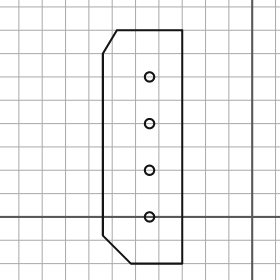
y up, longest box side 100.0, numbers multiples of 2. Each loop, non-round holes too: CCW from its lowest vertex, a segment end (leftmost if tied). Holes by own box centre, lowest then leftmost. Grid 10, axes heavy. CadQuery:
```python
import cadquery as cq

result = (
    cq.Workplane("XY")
    .moveTo(-52.0, -20.0)
    .lineTo(-30.0, -20.0)
    .lineTo(-30.0, 80.0)
    .lineTo(-58.0, 80.0)
    .lineTo(-64.0, 70.0)
    .lineTo(-64.0, -8.0)
    .close()
    .moveTo(-44.0, 0.0)
    .circle(2.0)
    .moveTo(-44.0, 20.0)
    .circle(2.0)
    .moveTo(-44.0, 40.0)
    .circle(2.0)
    .moveTo(-44.0, 60.0)
    .circle(2.0)
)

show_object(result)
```